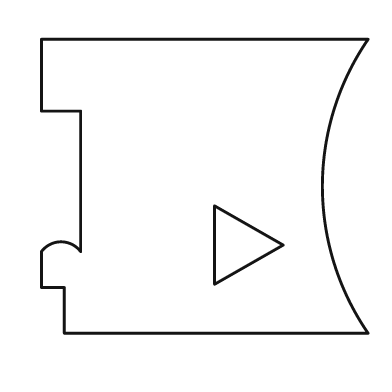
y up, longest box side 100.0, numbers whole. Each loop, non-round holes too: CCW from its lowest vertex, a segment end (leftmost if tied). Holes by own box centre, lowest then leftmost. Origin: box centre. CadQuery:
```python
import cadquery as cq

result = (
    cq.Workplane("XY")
    .moveTo(-43.0, -45.0)
    .lineTo(50.0, -45.0)
    .threePointArc((36.0, 0.0), (50.0, 45.0))
    .lineTo(-50.0, 45.0)
    .lineTo(-50.0, 23.0)
    .lineTo(-38.0, 23.0)
    .lineTo(-38.0, -20.0)
    .threePointArc((-44.0, -17.0), (-50.0, -20.0))
    .lineTo(-50.0, -31.0)
    .lineTo(-43.0, -31.0)
    .close()
    .moveTo(3.0, -30.0)
    .lineTo(24.0, -18.0)
    .lineTo(3.0, -6.0)
    .close()
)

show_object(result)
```